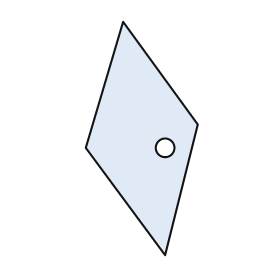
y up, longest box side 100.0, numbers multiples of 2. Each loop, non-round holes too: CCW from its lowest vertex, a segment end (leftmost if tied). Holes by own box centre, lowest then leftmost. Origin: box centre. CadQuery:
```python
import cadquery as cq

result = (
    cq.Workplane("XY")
    .moveTo(10.0, -50.0)
    .lineTo(24.0, 6.0)
    .lineTo(-8.0, 50.0)
    .lineTo(-24.0, -4.0)
    .close()
    .moveTo(10.0, -4.0)
    .circle(4.0)
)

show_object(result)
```